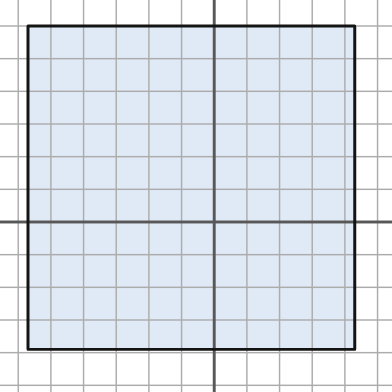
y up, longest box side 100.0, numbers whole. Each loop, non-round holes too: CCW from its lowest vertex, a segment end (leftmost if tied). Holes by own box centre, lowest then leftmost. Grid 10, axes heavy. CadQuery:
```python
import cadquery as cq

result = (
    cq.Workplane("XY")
    .moveTo(-57.0, -39.0)
    .lineTo(43.0, -39.0)
    .lineTo(43.0, 60.0)
    .lineTo(-57.0, 60.0)
    .close()
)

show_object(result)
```